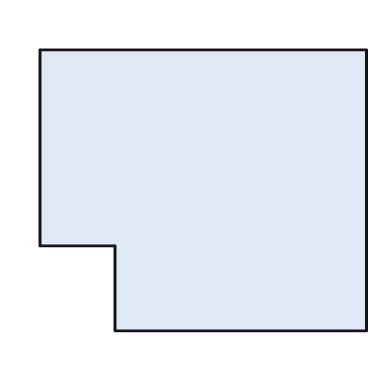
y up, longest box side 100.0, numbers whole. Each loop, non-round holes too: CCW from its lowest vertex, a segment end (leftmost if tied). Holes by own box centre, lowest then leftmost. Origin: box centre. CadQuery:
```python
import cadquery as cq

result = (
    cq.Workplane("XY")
    .moveTo(-27.0, -43.0)
    .lineTo(50.0, -43.0)
    .lineTo(50.0, 43.0)
    .lineTo(-50.0, 43.0)
    .lineTo(-50.0, -17.0)
    .lineTo(-27.0, -17.0)
    .close()
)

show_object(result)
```